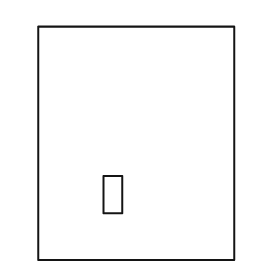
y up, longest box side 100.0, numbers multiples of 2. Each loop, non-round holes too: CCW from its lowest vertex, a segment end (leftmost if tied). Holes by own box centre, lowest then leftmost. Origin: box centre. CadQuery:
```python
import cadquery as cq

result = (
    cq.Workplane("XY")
    .moveTo(-42.0, -50.0)
    .lineTo(42.0, -50.0)
    .lineTo(42.0, 50.0)
    .lineTo(-42.0, 50.0)
    .close()
    .moveTo(-14.0, -30.0)
    .lineTo(-6.0, -30.0)
    .lineTo(-6.0, -14.0)
    .lineTo(-14.0, -14.0)
    .close()
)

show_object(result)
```